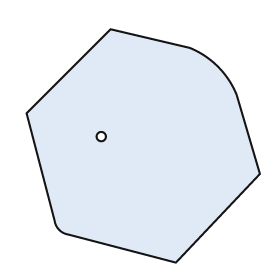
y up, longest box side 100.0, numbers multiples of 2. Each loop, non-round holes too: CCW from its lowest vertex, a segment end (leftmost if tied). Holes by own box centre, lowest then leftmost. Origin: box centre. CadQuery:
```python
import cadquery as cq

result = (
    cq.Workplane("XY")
    .moveTo(14.0, -50.0)
    .lineTo(50.0, -12.0)
    .lineTo(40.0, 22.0)
    .threePointArc((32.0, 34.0), (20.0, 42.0))
    .lineTo(-14.0, 50.0)
    .lineTo(-50.0, 14.0)
    .lineTo(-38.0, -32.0)
    .threePointArc((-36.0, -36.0), (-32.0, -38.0))
    .close()
    .moveTo(-18.0, 4.0)
    .circle(2.0)
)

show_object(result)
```